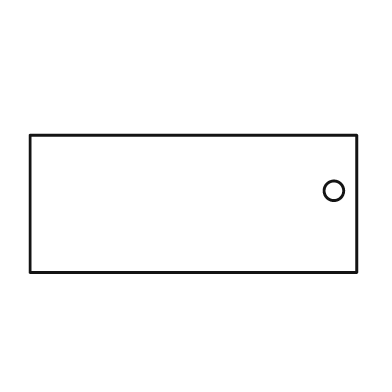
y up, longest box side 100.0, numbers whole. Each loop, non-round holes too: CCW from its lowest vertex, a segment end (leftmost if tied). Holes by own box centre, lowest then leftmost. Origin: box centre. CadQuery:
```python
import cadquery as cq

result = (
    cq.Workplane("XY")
    .moveTo(-50.0, -21.0)
    .lineTo(50.0, -21.0)
    .lineTo(50.0, 21.0)
    .lineTo(-50.0, 21.0)
    .close()
    .moveTo(43.0, 4.0)
    .circle(3.0)
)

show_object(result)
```